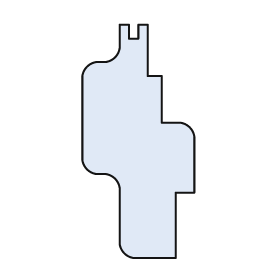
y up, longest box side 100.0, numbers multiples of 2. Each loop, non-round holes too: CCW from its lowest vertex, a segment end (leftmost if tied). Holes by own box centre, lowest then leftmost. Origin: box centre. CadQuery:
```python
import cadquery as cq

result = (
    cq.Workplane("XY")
    .moveTo(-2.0, -50.0)
    .lineTo(16.0, -50.0)
    .lineTo(16.0, -22.0)
    .lineTo(24.0, -22.0)
    .lineTo(24.0, 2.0)
    .threePointArc((22.0, 6.0), (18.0, 8.0))
    .lineTo(10.0, 8.0)
    .lineTo(10.0, 28.0)
    .lineTo(4.0, 28.0)
    .lineTo(4.0, 50.0)
    .lineTo(0.0, 50.0)
    .lineTo(0.0, 44.0)
    .lineTo(-4.0, 44.0)
    .lineTo(-4.0, 50.0)
    .lineTo(-8.0, 50.0)
    .lineTo(-8.0, 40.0)
    .threePointArc((-10.0, 36.0), (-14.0, 34.0))
    .lineTo(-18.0, 34.0)
    .threePointArc((-22.0, 32.0), (-24.0, 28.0))
    .lineTo(-24.0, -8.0)
    .threePointArc((-22.0, -12.0), (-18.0, -14.0))
    .lineTo(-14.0, -14.0)
    .threePointArc((-10.0, -16.0), (-8.0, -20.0))
    .lineTo(-8.0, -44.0)
    .threePointArc((-6.0, -48.0), (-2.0, -50.0))
    .close()
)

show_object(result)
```